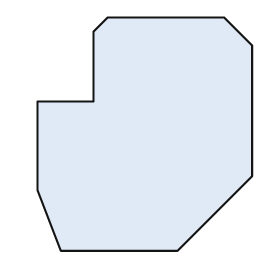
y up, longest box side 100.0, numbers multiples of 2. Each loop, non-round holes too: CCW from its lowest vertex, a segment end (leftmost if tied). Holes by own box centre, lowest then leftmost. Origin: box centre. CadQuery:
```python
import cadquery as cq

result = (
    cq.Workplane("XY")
    .moveTo(-36.0, -50.0)
    .lineTo(14.0, -50.0)
    .lineTo(46.0, -18.0)
    .lineTo(46.0, 38.0)
    .lineTo(34.0, 50.0)
    .lineTo(-16.0, 50.0)
    .lineTo(-22.0, 44.0)
    .lineTo(-22.0, 14.0)
    .lineTo(-46.0, 14.0)
    .lineTo(-46.0, -24.0)
    .close()
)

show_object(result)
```